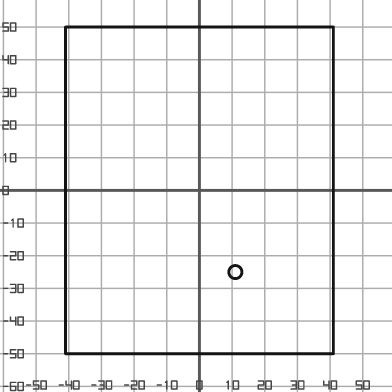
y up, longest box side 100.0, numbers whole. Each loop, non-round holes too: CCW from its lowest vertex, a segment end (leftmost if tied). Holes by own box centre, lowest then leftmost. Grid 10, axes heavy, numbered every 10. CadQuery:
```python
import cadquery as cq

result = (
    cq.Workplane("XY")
    .moveTo(-41.0, -50.0)
    .lineTo(41.0, -50.0)
    .lineTo(41.0, 50.0)
    .lineTo(-41.0, 50.0)
    .close()
    .moveTo(11.0, -25.0)
    .circle(2.0)
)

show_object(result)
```